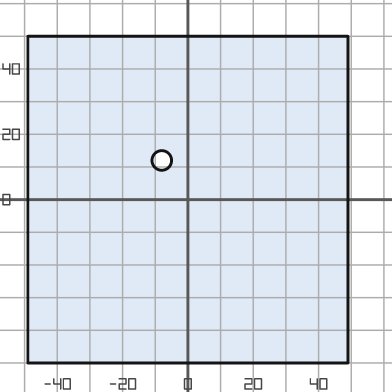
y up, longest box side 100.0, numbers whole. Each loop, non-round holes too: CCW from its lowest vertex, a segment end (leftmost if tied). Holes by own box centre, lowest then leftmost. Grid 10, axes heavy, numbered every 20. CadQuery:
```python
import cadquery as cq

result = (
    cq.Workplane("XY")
    .moveTo(-49.0, -50.0)
    .lineTo(49.0, -50.0)
    .lineTo(49.0, 50.0)
    .lineTo(-49.0, 50.0)
    .close()
    .moveTo(-8.0, 12.0)
    .circle(3.0)
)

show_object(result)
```